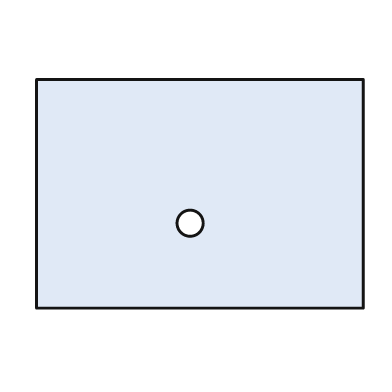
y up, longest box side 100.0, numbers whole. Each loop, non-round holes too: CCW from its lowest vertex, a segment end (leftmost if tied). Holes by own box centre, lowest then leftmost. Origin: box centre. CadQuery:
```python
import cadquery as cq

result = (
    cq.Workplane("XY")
    .moveTo(-50.0, -35.0)
    .lineTo(50.0, -35.0)
    .lineTo(50.0, 35.0)
    .lineTo(-50.0, 35.0)
    .close()
    .moveTo(-3.0, -9.0)
    .circle(4.0)
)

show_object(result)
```